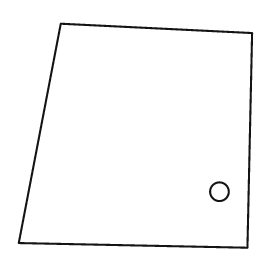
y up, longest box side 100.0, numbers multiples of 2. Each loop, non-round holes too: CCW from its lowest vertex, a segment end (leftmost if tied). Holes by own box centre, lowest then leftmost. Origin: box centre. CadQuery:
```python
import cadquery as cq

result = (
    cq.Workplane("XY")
    .moveTo(48.0, -48.0)
    .lineTo(50.0, 44.0)
    .lineTo(-32.0, 48.0)
    .lineTo(-50.0, -46.0)
    .close()
    .moveTo(36.0, -24.0)
    .circle(4.0)
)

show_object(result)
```